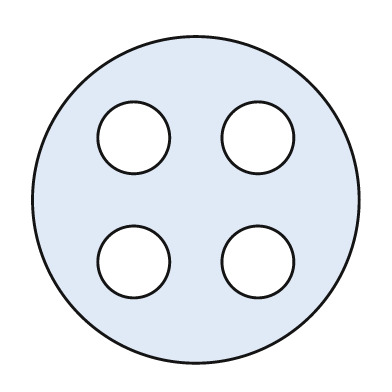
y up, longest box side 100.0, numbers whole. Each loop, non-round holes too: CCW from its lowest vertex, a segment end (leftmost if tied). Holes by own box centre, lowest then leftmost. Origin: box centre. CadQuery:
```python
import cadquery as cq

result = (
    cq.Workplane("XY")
    .moveTo(0.0, 0.0)
    .circle(50.0)
    .moveTo(-19.0, -19.0)
    .circle(11.0)
    .moveTo(19.0, -19.0)
    .circle(11.0)
    .moveTo(-19.0, 19.0)
    .circle(11.0)
    .moveTo(19.0, 19.0)
    .circle(11.0)
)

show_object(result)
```